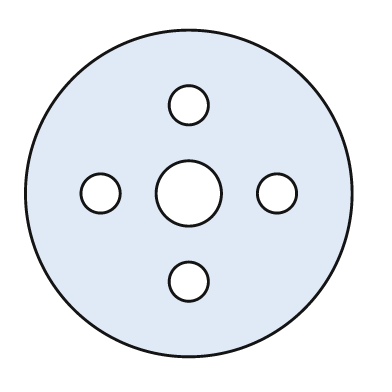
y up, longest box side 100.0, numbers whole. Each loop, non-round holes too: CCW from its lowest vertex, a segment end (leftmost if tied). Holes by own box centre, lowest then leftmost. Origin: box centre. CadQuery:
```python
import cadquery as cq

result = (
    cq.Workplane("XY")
    .moveTo(0.0, 0.0)
    .circle(50.0)
    .moveTo(0.0, -27.0)
    .circle(6.0)
    .moveTo(-27.0, 0.0)
    .circle(6.0)
    .moveTo(0.0, 0.0)
    .circle(10.0)
    .moveTo(27.0, 0.0)
    .circle(6.0)
    .moveTo(0.0, 27.0)
    .circle(6.0)
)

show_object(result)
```